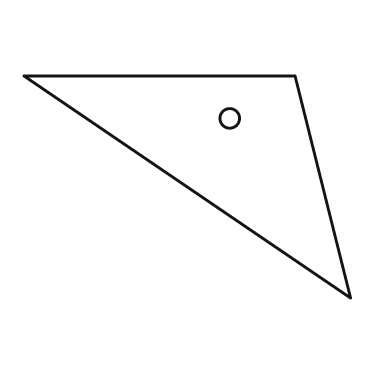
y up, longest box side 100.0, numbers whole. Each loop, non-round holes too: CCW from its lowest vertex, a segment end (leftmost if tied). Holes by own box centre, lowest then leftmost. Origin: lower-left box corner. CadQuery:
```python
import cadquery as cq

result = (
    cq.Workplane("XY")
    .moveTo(100.0, 0.0)
    .lineTo(83.0, 68.0)
    .lineTo(0.0, 68.0)
    .close()
    .moveTo(63.0, 55.0)
    .circle(3.0)
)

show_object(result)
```